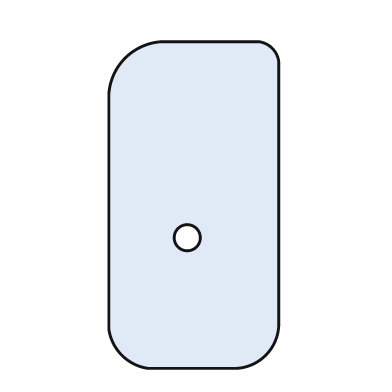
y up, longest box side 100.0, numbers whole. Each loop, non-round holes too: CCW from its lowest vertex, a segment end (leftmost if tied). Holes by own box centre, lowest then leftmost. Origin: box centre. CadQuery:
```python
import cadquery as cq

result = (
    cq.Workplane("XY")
    .moveTo(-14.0, -50.0)
    .lineTo(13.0, -50.0)
    .threePointArc((22.0, -46.0), (26.0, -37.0))
    .lineTo(26.0, 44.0)
    .threePointArc((24.0, 48.0), (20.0, 50.0))
    .lineTo(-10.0, 50.0)
    .threePointArc((-21.0, 45.0), (-26.0, 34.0))
    .lineTo(-26.0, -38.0)
    .threePointArc((-22.0, -46.0), (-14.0, -50.0))
    .close()
    .moveTo(-2.0, -10.0)
    .circle(4.0)
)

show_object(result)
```